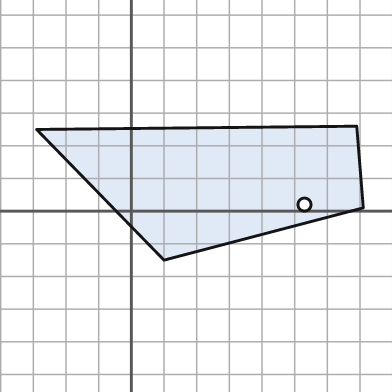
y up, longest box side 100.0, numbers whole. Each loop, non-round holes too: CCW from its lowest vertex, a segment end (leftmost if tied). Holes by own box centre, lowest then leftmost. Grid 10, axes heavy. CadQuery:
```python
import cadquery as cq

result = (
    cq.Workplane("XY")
    .moveTo(10.0, -15.0)
    .lineTo(71.0, 1.0)
    .lineTo(69.0, 26.0)
    .lineTo(-29.0, 25.0)
    .close()
    .moveTo(53.0, 2.0)
    .circle(2.0)
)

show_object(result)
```